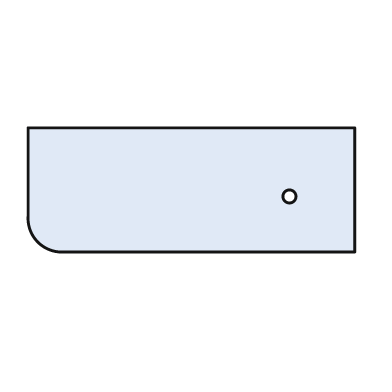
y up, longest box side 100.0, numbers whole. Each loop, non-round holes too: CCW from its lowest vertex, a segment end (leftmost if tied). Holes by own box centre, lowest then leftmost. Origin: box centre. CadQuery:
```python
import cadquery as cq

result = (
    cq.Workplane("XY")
    .moveTo(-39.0, -19.0)
    .lineTo(50.0, -19.0)
    .lineTo(50.0, 19.0)
    .lineTo(-50.0, 19.0)
    .lineTo(-50.0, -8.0)
    .threePointArc((-47.0, -16.0), (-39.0, -19.0))
    .close()
    .moveTo(30.0, -2.0)
    .circle(2.0)
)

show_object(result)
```